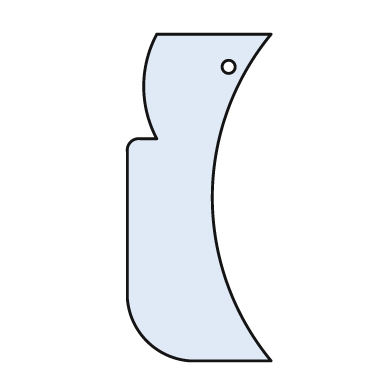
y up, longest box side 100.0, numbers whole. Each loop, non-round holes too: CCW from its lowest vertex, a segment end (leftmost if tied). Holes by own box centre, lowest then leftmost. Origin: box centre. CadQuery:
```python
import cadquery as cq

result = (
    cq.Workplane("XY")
    .moveTo(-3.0, -50.0)
    .lineTo(22.0, -50.0)
    .threePointArc((4.0, 0.0), (22.0, 50.0))
    .lineTo(-13.0, 50.0)
    .threePointArc((-17.0, 34.0), (-13.0, 18.0))
    .lineTo(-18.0, 18.0)
    .threePointArc((-21.0, 17.0), (-22.0, 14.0))
    .lineTo(-22.0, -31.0)
    .threePointArc((-16.0, -44.0), (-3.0, -50.0))
    .close()
    .moveTo(9.0, 40.0)
    .circle(2.0)
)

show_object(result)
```